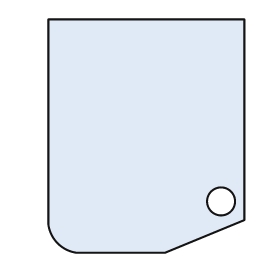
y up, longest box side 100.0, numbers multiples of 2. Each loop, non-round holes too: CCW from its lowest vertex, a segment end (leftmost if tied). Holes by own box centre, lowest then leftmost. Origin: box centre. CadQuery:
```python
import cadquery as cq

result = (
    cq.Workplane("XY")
    .moveTo(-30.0, -50.0)
    .lineTo(8.0, -50.0)
    .lineTo(42.0, -36.0)
    .lineTo(42.0, 50.0)
    .lineTo(-42.0, 50.0)
    .lineTo(-42.0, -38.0)
    .threePointArc((-38.0, -46.0), (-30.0, -50.0))
    .close()
    .moveTo(32.0, -28.0)
    .circle(6.0)
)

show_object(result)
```